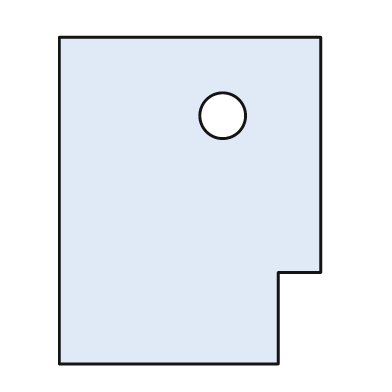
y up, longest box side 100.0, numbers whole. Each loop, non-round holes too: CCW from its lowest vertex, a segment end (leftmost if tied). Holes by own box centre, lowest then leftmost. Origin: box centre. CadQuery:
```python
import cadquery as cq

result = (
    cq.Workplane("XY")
    .moveTo(-40.0, -50.0)
    .lineTo(27.0, -50.0)
    .lineTo(27.0, -22.0)
    .lineTo(40.0, -22.0)
    .lineTo(40.0, 50.0)
    .lineTo(-40.0, 50.0)
    .close()
    .moveTo(10.0, 26.0)
    .circle(7.0)
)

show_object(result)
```